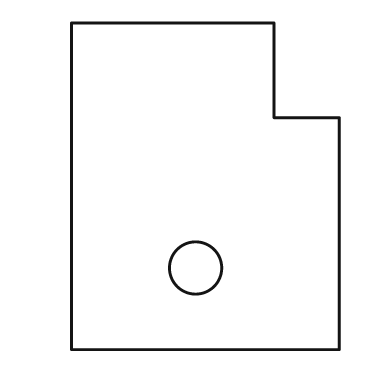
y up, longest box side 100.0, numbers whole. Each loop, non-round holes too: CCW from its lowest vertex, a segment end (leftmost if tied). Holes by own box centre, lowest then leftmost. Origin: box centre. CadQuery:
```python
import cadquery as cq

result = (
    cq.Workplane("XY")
    .moveTo(-41.0, -50.0)
    .lineTo(41.0, -50.0)
    .lineTo(41.0, 21.0)
    .lineTo(21.0, 21.0)
    .lineTo(21.0, 50.0)
    .lineTo(-41.0, 50.0)
    .close()
    .moveTo(-3.0, -25.0)
    .circle(8.0)
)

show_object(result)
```